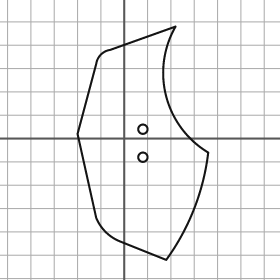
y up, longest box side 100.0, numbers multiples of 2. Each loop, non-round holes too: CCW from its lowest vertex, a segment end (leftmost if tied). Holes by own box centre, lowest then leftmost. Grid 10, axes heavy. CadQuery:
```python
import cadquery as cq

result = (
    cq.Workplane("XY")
    .moveTo(18.0, -52.0)
    .threePointArc((30.0, -30.0), (36.0, -6.0))
    .threePointArc((18.0, 18.0), (22.0, 48.0))
    .lineTo(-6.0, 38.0)
    .threePointArc((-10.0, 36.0), (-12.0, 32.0))
    .lineTo(-20.0, 2.0)
    .lineTo(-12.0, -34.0)
    .threePointArc((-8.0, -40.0), (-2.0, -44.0))
    .close()
    .moveTo(8.0, -8.0)
    .circle(2.0)
    .moveTo(8.0, 4.0)
    .circle(2.0)
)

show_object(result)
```